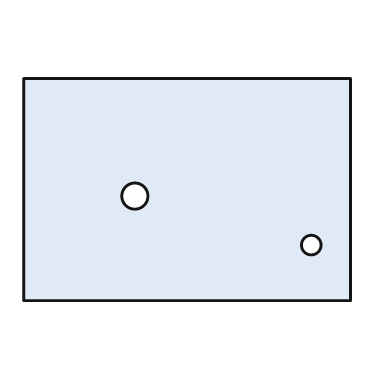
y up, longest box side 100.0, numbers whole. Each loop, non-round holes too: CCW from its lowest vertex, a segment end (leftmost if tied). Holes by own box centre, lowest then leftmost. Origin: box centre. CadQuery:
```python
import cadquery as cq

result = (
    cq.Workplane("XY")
    .moveTo(-50.0, -34.0)
    .lineTo(50.0, -34.0)
    .lineTo(50.0, 34.0)
    .lineTo(-50.0, 34.0)
    .close()
    .moveTo(38.0, -17.0)
    .circle(3.0)
    .moveTo(-16.0, -2.0)
    .circle(4.0)
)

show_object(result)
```